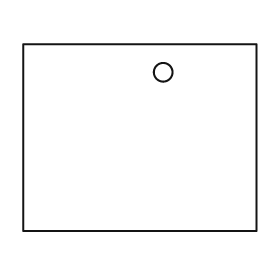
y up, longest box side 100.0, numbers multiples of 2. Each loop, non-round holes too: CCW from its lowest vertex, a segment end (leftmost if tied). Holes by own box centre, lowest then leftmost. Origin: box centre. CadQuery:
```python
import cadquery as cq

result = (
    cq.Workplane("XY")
    .moveTo(-50.0, -40.0)
    .lineTo(50.0, -40.0)
    .lineTo(50.0, 40.0)
    .lineTo(-50.0, 40.0)
    .close()
    .moveTo(10.0, 28.0)
    .circle(4.0)
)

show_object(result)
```